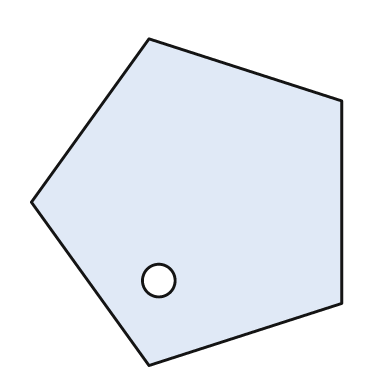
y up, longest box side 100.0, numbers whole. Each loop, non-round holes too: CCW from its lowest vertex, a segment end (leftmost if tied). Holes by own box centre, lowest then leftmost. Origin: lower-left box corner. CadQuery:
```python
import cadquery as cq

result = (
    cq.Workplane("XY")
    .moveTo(36.0, 0.0)
    .lineTo(95.0, 19.0)
    .lineTo(95.0, 81.0)
    .lineTo(36.0, 100.0)
    .lineTo(0.0, 50.0)
    .close()
    .moveTo(39.0, 26.0)
    .circle(5.0)
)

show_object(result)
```